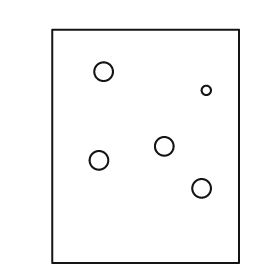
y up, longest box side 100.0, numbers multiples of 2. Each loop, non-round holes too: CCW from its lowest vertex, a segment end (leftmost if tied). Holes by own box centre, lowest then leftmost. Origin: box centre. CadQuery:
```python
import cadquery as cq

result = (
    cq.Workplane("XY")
    .moveTo(-40.0, -50.0)
    .lineTo(40.0, -50.0)
    .lineTo(40.0, 50.0)
    .lineTo(-40.0, 50.0)
    .close()
    .moveTo(24.0, -18.0)
    .circle(4.0)
    .moveTo(-20.0, -6.0)
    .circle(4.0)
    .moveTo(8.0, 0.0)
    .circle(4.0)
    .moveTo(26.0, 24.0)
    .circle(2.0)
    .moveTo(-18.0, 32.0)
    .circle(4.0)
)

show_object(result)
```